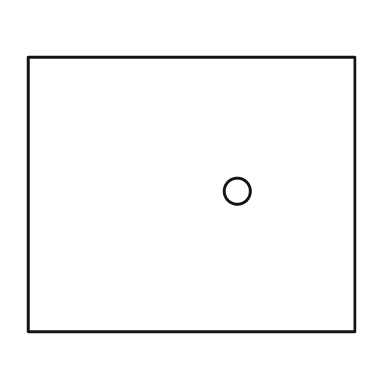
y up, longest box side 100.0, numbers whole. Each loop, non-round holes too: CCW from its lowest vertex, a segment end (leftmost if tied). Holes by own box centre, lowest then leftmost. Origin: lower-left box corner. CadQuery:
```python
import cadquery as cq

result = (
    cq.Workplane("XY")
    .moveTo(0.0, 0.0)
    .lineTo(100.0, 0.0)
    .lineTo(100.0, 84.0)
    .lineTo(0.0, 84.0)
    .close()
    .moveTo(64.0, 43.0)
    .circle(4.0)
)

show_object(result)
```